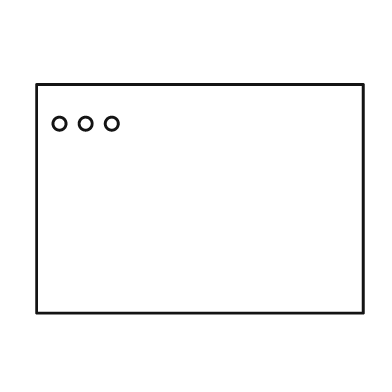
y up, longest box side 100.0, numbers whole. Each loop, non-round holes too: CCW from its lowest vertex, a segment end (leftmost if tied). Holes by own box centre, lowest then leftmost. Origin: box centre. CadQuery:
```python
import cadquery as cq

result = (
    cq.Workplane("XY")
    .moveTo(-50.0, -35.0)
    .lineTo(50.0, -35.0)
    .lineTo(50.0, 35.0)
    .lineTo(-50.0, 35.0)
    .close()
    .moveTo(-43.0, 23.0)
    .circle(2.0)
    .moveTo(-35.0, 23.0)
    .circle(2.0)
    .moveTo(-27.0, 23.0)
    .circle(2.0)
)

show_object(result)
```